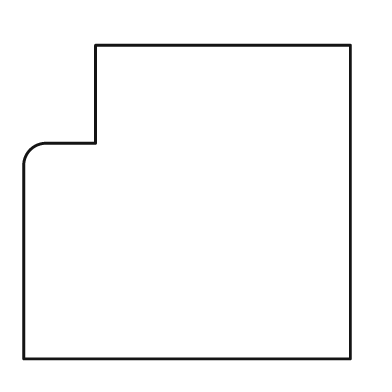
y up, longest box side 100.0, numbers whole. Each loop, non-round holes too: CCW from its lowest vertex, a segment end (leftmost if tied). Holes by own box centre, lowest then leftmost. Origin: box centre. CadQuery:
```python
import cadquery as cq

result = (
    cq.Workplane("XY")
    .moveTo(-50.0, -48.0)
    .lineTo(50.0, -48.0)
    .lineTo(50.0, 48.0)
    .lineTo(-28.0, 48.0)
    .lineTo(-28.0, 18.0)
    .lineTo(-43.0, 18.0)
    .threePointArc((-48.0, 16.0), (-50.0, 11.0))
    .close()
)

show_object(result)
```